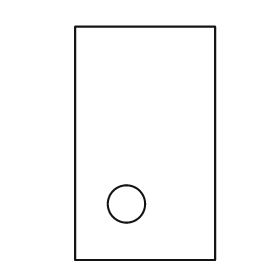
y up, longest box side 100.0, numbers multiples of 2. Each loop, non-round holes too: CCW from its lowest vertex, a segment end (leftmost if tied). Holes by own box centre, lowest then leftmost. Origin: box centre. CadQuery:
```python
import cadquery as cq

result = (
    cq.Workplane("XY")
    .moveTo(-30.0, -50.0)
    .lineTo(30.0, -50.0)
    .lineTo(30.0, 50.0)
    .lineTo(-30.0, 50.0)
    .close()
    .moveTo(-8.0, -26.0)
    .circle(8.0)
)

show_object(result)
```